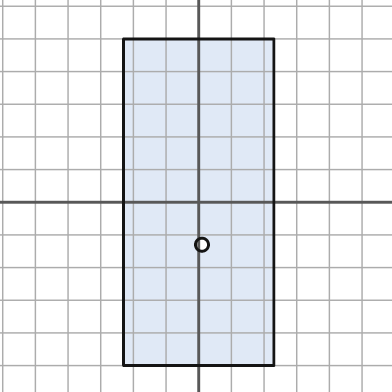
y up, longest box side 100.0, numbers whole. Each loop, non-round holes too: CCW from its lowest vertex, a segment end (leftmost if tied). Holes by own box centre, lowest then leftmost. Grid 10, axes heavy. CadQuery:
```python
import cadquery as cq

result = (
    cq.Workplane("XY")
    .moveTo(-23.0, -50.0)
    .lineTo(23.0, -50.0)
    .lineTo(23.0, 50.0)
    .lineTo(-23.0, 50.0)
    .close()
    .moveTo(1.0, -13.0)
    .circle(2.0)
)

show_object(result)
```